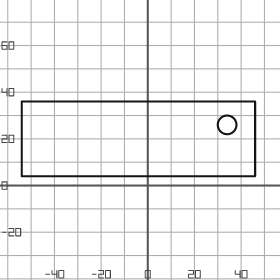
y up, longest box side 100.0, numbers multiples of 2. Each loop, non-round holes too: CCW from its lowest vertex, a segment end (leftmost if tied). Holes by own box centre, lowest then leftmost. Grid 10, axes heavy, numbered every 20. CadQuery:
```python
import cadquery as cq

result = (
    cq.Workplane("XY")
    .moveTo(-54.0, 4.0)
    .lineTo(46.0, 4.0)
    .lineTo(46.0, 36.0)
    .lineTo(-54.0, 36.0)
    .close()
    .moveTo(34.0, 26.0)
    .circle(4.0)
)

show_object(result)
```